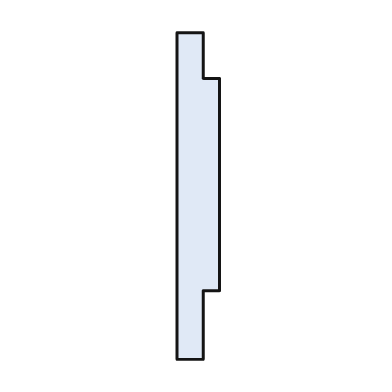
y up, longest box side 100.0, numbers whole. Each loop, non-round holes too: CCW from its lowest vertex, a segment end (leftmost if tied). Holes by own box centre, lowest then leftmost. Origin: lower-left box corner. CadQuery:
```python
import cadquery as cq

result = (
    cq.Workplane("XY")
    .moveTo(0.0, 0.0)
    .lineTo(8.0, 0.0)
    .lineTo(8.0, 21.0)
    .lineTo(13.0, 21.0)
    .lineTo(13.0, 86.0)
    .lineTo(8.0, 86.0)
    .lineTo(8.0, 100.0)
    .lineTo(0.0, 100.0)
    .close()
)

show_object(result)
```